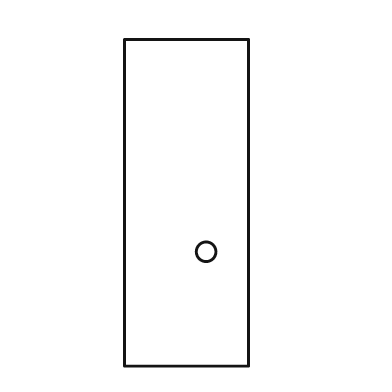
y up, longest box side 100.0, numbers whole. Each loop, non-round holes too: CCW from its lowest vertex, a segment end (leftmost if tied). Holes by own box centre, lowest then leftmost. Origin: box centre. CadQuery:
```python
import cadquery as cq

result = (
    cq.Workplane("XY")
    .moveTo(-19.0, -50.0)
    .lineTo(19.0, -50.0)
    .lineTo(19.0, 50.0)
    .lineTo(-19.0, 50.0)
    .close()
    .moveTo(6.0, -15.0)
    .circle(3.0)
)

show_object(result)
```